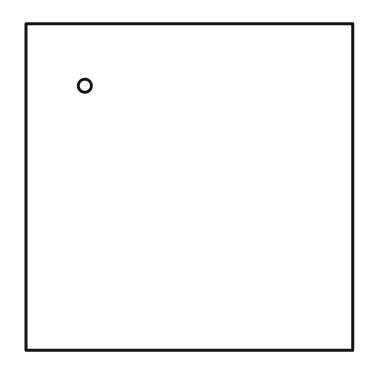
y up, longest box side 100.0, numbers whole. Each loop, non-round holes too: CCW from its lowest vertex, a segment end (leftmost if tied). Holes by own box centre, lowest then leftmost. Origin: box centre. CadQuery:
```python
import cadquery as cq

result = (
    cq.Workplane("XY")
    .moveTo(-50.0, -50.0)
    .lineTo(50.0, -50.0)
    .lineTo(50.0, 50.0)
    .lineTo(-50.0, 50.0)
    .close()
    .moveTo(-32.0, 31.0)
    .circle(2.0)
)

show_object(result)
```